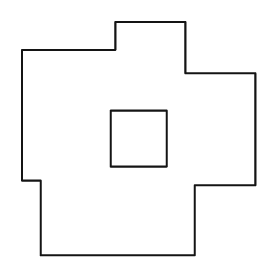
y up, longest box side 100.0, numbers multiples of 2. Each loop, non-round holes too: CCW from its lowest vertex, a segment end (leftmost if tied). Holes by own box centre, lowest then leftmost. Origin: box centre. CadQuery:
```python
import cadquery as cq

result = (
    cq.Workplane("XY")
    .moveTo(-42.0, -50.0)
    .lineTo(24.0, -50.0)
    .lineTo(24.0, -20.0)
    .lineTo(50.0, -20.0)
    .lineTo(50.0, 28.0)
    .lineTo(20.0, 28.0)
    .lineTo(20.0, 50.0)
    .lineTo(-10.0, 50.0)
    .lineTo(-10.0, 38.0)
    .lineTo(-50.0, 38.0)
    .lineTo(-50.0, -18.0)
    .lineTo(-42.0, -18.0)
    .close()
    .moveTo(-12.0, -12.0)
    .lineTo(12.0, -12.0)
    .lineTo(12.0, 12.0)
    .lineTo(-12.0, 12.0)
    .close()
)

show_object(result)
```